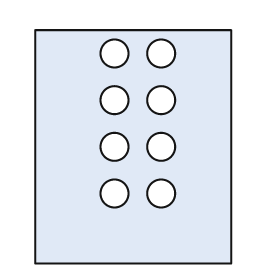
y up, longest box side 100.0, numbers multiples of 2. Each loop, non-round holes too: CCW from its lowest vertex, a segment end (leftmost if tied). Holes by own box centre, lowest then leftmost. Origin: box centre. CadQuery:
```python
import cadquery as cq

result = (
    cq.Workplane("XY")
    .moveTo(-42.0, -50.0)
    .lineTo(42.0, -50.0)
    .lineTo(42.0, 50.0)
    .lineTo(-42.0, 50.0)
    .close()
    .moveTo(-8.0, -20.0)
    .circle(6.0)
    .moveTo(12.0, -20.0)
    .circle(6.0)
    .moveTo(-8.0, 0.0)
    .circle(6.0)
    .moveTo(12.0, 0.0)
    .circle(6.0)
    .moveTo(-8.0, 20.0)
    .circle(6.0)
    .moveTo(12.0, 20.0)
    .circle(6.0)
    .moveTo(-8.0, 40.0)
    .circle(6.0)
    .moveTo(12.0, 40.0)
    .circle(6.0)
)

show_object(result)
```